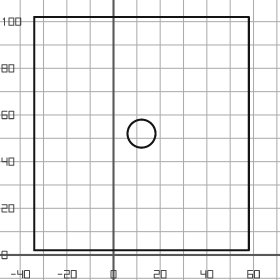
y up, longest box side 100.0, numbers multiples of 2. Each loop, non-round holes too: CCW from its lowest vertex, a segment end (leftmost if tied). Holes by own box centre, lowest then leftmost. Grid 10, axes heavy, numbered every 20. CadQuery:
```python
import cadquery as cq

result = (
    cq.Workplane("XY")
    .moveTo(-34.0, 2.0)
    .lineTo(58.0, 2.0)
    .lineTo(58.0, 102.0)
    .lineTo(-34.0, 102.0)
    .close()
    .moveTo(12.0, 52.0)
    .circle(6.0)
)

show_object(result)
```